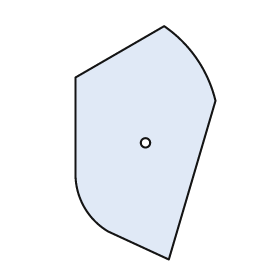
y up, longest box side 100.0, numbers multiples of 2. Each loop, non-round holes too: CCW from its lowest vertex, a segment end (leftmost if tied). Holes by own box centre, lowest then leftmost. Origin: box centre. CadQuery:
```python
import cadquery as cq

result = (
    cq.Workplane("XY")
    .moveTo(10.0, -50.0)
    .lineTo(30.0, 18.0)
    .threePointArc((22.0, 36.0), (8.0, 50.0))
    .lineTo(-30.0, 28.0)
    .lineTo(-30.0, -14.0)
    .threePointArc((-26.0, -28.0), (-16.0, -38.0))
    .close()
    .moveTo(0.0, 0.0)
    .circle(2.0)
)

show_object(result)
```